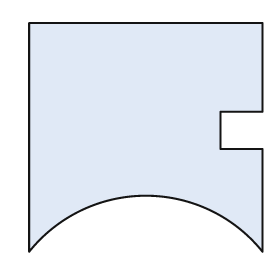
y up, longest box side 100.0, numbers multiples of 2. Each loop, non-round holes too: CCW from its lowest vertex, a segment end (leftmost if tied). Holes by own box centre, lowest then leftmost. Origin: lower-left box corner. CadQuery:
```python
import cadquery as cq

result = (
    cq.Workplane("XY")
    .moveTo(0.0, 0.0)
    .threePointArc((50.0, 24.0), (100.0, 0.0))
    .lineTo(100.0, 44.0)
    .lineTo(82.0, 44.0)
    .lineTo(82.0, 60.0)
    .lineTo(100.0, 60.0)
    .lineTo(100.0, 98.0)
    .lineTo(0.0, 98.0)
    .close()
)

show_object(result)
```